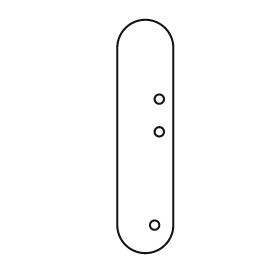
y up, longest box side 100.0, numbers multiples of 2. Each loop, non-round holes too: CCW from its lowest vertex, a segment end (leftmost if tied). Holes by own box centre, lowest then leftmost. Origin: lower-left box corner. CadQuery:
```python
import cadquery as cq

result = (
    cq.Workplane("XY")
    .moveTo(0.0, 12.0)
    .threePointArc((12.0, 0.0), (24.0, 12.0))
    .lineTo(24.0, 88.0)
    .threePointArc((12.0, 100.0), (0.0, 88.0))
    .close()
    .moveTo(16.0, 12.0)
    .circle(2.0)
    .moveTo(18.0, 52.0)
    .circle(2.0)
    .moveTo(18.0, 66.0)
    .circle(2.0)
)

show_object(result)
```